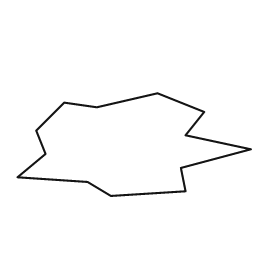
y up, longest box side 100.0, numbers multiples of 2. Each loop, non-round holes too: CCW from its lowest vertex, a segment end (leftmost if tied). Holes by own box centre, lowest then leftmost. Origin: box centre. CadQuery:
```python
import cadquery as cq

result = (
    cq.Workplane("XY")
    .moveTo(-10.0, -22.0)
    .lineTo(22.0, -20.0)
    .lineTo(20.0, -10.0)
    .lineTo(50.0, -2.0)
    .lineTo(22.0, 4.0)
    .lineTo(30.0, 14.0)
    .lineTo(10.0, 22.0)
    .lineTo(-16.0, 16.0)
    .lineTo(-30.0, 18.0)
    .lineTo(-42.0, 6.0)
    .lineTo(-38.0, -4.0)
    .lineTo(-50.0, -14.0)
    .lineTo(-20.0, -16.0)
    .close()
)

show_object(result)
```